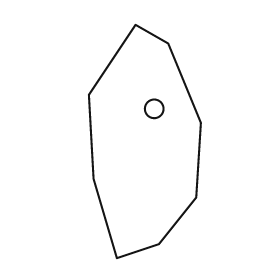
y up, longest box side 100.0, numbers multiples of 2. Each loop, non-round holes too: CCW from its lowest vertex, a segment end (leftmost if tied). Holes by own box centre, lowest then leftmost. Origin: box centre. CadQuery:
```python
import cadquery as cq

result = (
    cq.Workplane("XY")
    .moveTo(-12.0, -50.0)
    .lineTo(6.0, -44.0)
    .lineTo(22.0, -24.0)
    .lineTo(24.0, 8.0)
    .lineTo(10.0, 42.0)
    .lineTo(-4.0, 50.0)
    .lineTo(-24.0, 20.0)
    .lineTo(-22.0, -16.0)
    .close()
    .moveTo(4.0, 14.0)
    .circle(4.0)
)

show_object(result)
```